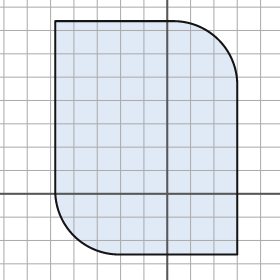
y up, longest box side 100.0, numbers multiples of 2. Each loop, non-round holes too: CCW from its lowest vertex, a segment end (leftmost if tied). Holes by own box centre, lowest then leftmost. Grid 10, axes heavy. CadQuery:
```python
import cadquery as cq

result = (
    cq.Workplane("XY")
    .moveTo(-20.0, -26.0)
    .lineTo(30.0, -26.0)
    .lineTo(30.0, 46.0)
    .threePointArc((22.0, 66.0), (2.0, 74.0))
    .lineTo(-48.0, 74.0)
    .lineTo(-48.0, 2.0)
    .threePointArc((-40.0, -18.0), (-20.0, -26.0))
    .close()
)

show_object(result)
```